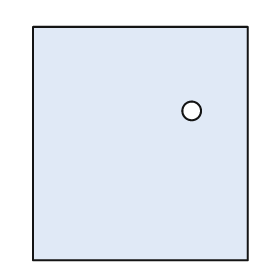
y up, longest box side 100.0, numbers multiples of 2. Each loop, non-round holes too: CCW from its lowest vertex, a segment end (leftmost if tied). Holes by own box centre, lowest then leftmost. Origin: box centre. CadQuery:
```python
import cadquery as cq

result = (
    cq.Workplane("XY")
    .moveTo(-46.0, -50.0)
    .lineTo(46.0, -50.0)
    .lineTo(46.0, 50.0)
    .lineTo(-46.0, 50.0)
    .close()
    .moveTo(22.0, 14.0)
    .circle(4.0)
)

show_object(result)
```